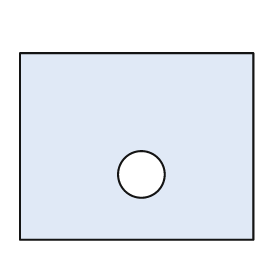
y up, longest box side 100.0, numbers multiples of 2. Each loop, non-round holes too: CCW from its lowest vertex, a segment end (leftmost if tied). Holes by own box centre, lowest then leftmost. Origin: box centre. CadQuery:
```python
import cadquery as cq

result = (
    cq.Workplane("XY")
    .moveTo(-50.0, -40.0)
    .lineTo(50.0, -40.0)
    .lineTo(50.0, 40.0)
    .lineTo(-50.0, 40.0)
    .close()
    .moveTo(2.0, -12.0)
    .circle(10.0)
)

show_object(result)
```